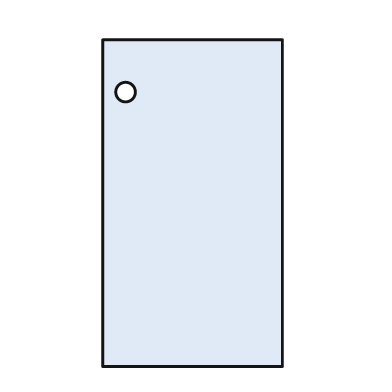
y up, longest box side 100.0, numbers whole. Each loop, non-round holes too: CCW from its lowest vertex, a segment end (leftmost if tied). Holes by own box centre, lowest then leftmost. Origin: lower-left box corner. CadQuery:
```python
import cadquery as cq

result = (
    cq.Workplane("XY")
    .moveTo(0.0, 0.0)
    .lineTo(55.0, 0.0)
    .lineTo(55.0, 100.0)
    .lineTo(0.0, 100.0)
    .close()
    .moveTo(7.0, 84.0)
    .circle(3.0)
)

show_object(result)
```